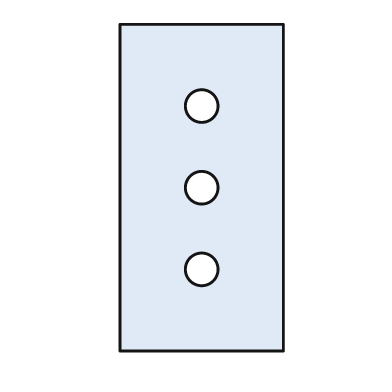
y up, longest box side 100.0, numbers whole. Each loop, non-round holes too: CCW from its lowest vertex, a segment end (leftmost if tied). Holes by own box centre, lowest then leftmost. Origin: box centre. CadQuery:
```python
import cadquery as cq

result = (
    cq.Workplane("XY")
    .moveTo(-25.0, -50.0)
    .lineTo(25.0, -50.0)
    .lineTo(25.0, 50.0)
    .lineTo(-25.0, 50.0)
    .close()
    .moveTo(0.0, -25.0)
    .circle(5.0)
    .moveTo(0.0, 0.0)
    .circle(5.0)
    .moveTo(0.0, 25.0)
    .circle(5.0)
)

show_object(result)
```